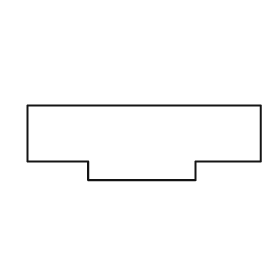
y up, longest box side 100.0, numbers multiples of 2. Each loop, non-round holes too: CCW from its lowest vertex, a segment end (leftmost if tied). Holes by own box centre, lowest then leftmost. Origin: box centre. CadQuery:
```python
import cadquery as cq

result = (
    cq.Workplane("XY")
    .moveTo(-24.0, -16.0)
    .lineTo(22.0, -16.0)
    .lineTo(22.0, -8.0)
    .lineTo(50.0, -8.0)
    .lineTo(50.0, 16.0)
    .lineTo(-50.0, 16.0)
    .lineTo(-50.0, -8.0)
    .lineTo(-24.0, -8.0)
    .close()
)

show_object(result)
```